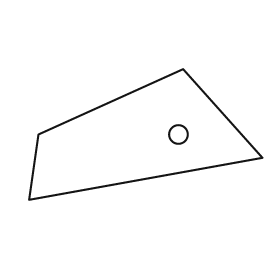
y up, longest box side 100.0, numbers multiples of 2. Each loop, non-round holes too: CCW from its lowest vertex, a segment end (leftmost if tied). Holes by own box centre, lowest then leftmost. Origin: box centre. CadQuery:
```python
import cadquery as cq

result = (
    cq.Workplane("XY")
    .moveTo(-50.0, -28.0)
    .lineTo(50.0, -10.0)
    .lineTo(16.0, 28.0)
    .lineTo(-46.0, 0.0)
    .close()
    .moveTo(14.0, 0.0)
    .circle(4.0)
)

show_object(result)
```